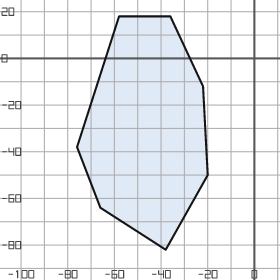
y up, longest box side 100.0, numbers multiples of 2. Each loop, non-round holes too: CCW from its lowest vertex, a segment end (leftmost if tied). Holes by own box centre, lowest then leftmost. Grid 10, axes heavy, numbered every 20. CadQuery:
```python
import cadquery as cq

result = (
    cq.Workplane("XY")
    .moveTo(-38.0, -82.0)
    .lineTo(-20.0, -50.0)
    .lineTo(-22.0, -12.0)
    .lineTo(-36.0, 18.0)
    .lineTo(-58.0, 18.0)
    .lineTo(-76.0, -38.0)
    .lineTo(-66.0, -64.0)
    .close()
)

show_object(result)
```